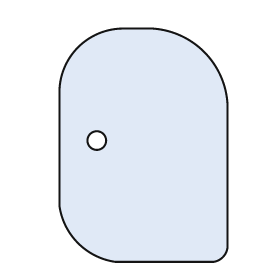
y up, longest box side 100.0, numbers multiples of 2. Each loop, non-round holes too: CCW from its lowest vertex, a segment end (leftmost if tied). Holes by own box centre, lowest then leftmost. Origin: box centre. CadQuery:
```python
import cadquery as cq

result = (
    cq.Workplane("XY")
    .moveTo(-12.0, -50.0)
    .lineTo(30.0, -50.0)
    .threePointArc((34.0, -48.0), (36.0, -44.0))
    .lineTo(36.0, 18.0)
    .threePointArc((26.0, 40.0), (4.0, 50.0))
    .lineTo(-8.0, 50.0)
    .threePointArc((-28.0, 42.0), (-36.0, 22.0))
    .lineTo(-36.0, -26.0)
    .threePointArc((-28.0, -42.0), (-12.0, -50.0))
    .close()
    .moveTo(-20.0, 2.0)
    .circle(4.0)
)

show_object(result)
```